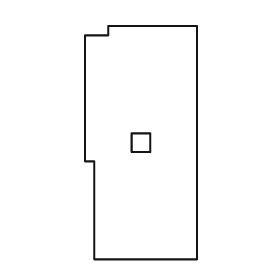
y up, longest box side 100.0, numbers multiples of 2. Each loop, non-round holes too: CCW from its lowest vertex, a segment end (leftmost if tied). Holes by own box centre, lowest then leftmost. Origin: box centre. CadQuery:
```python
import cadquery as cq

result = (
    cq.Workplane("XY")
    .moveTo(-20.0, -50.0)
    .lineTo(24.0, -50.0)
    .lineTo(24.0, 50.0)
    .lineTo(-14.0, 50.0)
    .lineTo(-14.0, 46.0)
    .lineTo(-24.0, 46.0)
    .lineTo(-24.0, -8.0)
    .lineTo(-20.0, -8.0)
    .close()
    .moveTo(-4.0, -4.0)
    .lineTo(4.0, -4.0)
    .lineTo(4.0, 4.0)
    .lineTo(-4.0, 4.0)
    .close()
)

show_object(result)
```